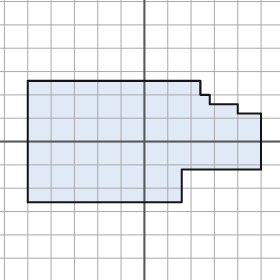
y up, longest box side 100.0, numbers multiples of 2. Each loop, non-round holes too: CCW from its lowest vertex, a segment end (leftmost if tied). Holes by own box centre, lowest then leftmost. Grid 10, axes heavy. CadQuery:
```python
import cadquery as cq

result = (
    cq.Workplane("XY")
    .moveTo(-50.0, -26.0)
    .lineTo(16.0, -26.0)
    .lineTo(16.0, -12.0)
    .lineTo(50.0, -12.0)
    .lineTo(50.0, 12.0)
    .lineTo(40.0, 12.0)
    .lineTo(40.0, 16.0)
    .lineTo(28.0, 16.0)
    .lineTo(28.0, 20.0)
    .lineTo(24.0, 20.0)
    .lineTo(24.0, 26.0)
    .lineTo(-50.0, 26.0)
    .close()
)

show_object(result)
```